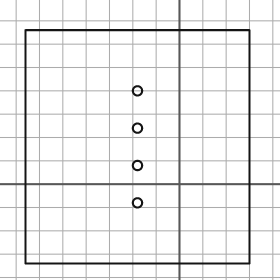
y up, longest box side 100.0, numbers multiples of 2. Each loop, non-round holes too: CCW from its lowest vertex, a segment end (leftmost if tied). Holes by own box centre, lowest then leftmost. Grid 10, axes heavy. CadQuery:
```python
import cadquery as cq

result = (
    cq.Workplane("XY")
    .moveTo(-66.0, -34.0)
    .lineTo(30.0, -34.0)
    .lineTo(30.0, 66.0)
    .lineTo(-66.0, 66.0)
    .close()
    .moveTo(-18.0, -8.0)
    .circle(2.0)
    .moveTo(-18.0, 8.0)
    .circle(2.0)
    .moveTo(-18.0, 24.0)
    .circle(2.0)
    .moveTo(-18.0, 40.0)
    .circle(2.0)
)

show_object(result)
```